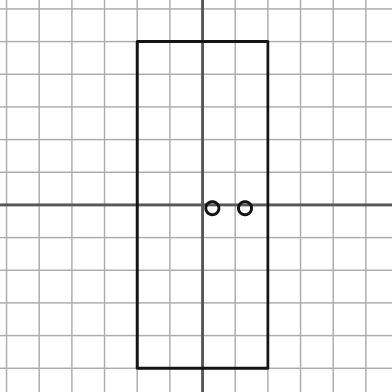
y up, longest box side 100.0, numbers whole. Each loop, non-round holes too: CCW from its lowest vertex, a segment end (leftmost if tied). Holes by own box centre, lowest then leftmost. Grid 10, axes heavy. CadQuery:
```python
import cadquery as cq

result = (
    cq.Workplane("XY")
    .moveTo(-20.0, -50.0)
    .lineTo(20.0, -50.0)
    .lineTo(20.0, 50.0)
    .lineTo(-20.0, 50.0)
    .close()
    .moveTo(3.0, -1.0)
    .circle(2.0)
    .moveTo(13.0, -1.0)
    .circle(2.0)
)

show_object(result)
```